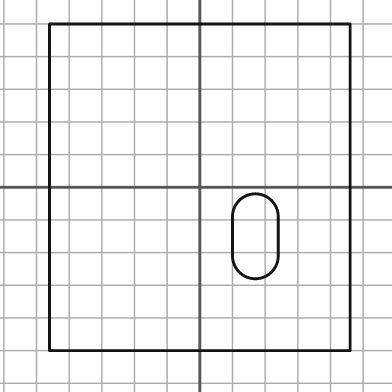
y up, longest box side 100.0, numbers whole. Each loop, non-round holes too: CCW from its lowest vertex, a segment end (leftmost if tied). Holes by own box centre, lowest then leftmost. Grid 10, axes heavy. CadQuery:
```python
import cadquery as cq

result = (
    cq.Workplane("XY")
    .moveTo(-46.0, -50.0)
    .lineTo(46.0, -50.0)
    .lineTo(46.0, 50.0)
    .lineTo(-46.0, 50.0)
    .close()
    .moveTo(10.0, -21.0)
    .threePointArc((17.0, -28.0), (24.0, -21.0))
    .lineTo(24.0, -9.0)
    .threePointArc((17.0, -2.0), (10.0, -9.0))
    .close()
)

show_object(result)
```